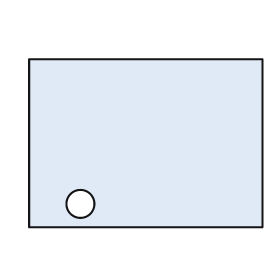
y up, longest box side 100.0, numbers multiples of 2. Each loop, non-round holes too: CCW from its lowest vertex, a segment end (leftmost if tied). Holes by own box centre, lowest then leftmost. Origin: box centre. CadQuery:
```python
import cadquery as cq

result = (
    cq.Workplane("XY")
    .moveTo(-50.0, -36.0)
    .lineTo(50.0, -36.0)
    .lineTo(50.0, 36.0)
    .lineTo(-50.0, 36.0)
    .close()
    .moveTo(-28.0, -26.0)
    .circle(6.0)
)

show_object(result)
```